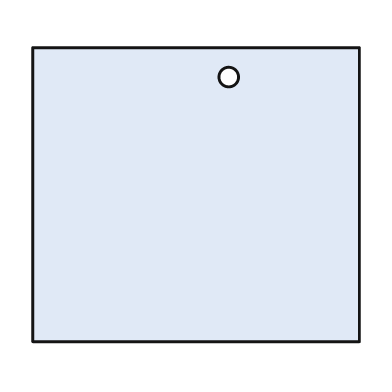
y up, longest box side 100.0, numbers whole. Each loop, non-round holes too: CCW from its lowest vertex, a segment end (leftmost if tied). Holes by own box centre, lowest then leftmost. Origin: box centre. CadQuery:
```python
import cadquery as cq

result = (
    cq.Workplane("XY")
    .moveTo(-50.0, -45.0)
    .lineTo(50.0, -45.0)
    .lineTo(50.0, 45.0)
    .lineTo(-50.0, 45.0)
    .close()
    .moveTo(10.0, 36.0)
    .circle(3.0)
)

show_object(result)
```